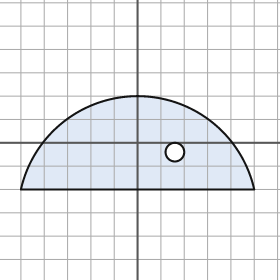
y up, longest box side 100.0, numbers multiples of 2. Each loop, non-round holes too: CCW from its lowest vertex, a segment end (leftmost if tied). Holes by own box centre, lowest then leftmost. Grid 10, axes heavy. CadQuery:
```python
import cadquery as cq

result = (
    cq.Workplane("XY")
    .moveTo(-50.0, -20.0)
    .lineTo(50.0, -20.0)
    .threePointArc((0.0, 20.0), (-50.0, -20.0))
    .close()
    .moveTo(16.0, -4.0)
    .circle(4.0)
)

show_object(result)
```